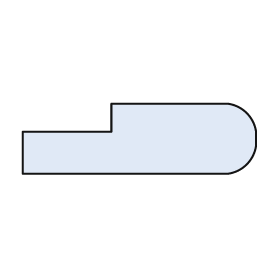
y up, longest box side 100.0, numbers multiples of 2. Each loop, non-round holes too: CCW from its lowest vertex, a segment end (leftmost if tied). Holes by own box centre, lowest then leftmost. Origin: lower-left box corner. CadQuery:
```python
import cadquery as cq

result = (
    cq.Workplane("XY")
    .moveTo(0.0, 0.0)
    .lineTo(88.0, 0.0)
    .threePointArc((96.0, 4.0), (100.0, 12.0))
    .lineTo(100.0, 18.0)
    .threePointArc((96.0, 26.0), (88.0, 30.0))
    .lineTo(38.0, 30.0)
    .lineTo(38.0, 18.0)
    .lineTo(0.0, 18.0)
    .close()
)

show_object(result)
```